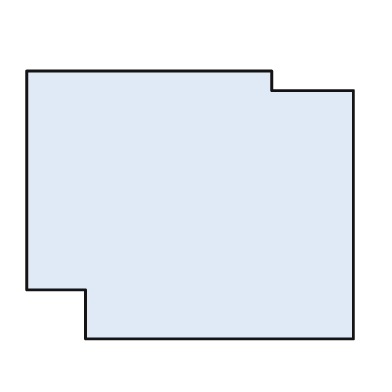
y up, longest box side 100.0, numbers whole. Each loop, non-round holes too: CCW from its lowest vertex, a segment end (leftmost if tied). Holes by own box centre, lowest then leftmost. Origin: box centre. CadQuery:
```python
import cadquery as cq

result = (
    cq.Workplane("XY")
    .moveTo(-32.0, -41.0)
    .lineTo(50.0, -41.0)
    .lineTo(50.0, 35.0)
    .lineTo(25.0, 35.0)
    .lineTo(25.0, 41.0)
    .lineTo(-50.0, 41.0)
    .lineTo(-50.0, -26.0)
    .lineTo(-32.0, -26.0)
    .close()
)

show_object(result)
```